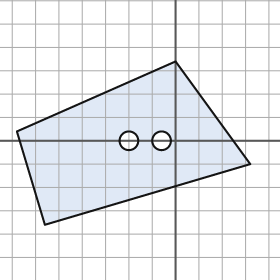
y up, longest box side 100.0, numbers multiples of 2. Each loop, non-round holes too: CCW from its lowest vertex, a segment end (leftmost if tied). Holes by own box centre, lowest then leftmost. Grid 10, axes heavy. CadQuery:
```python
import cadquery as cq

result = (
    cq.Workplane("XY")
    .moveTo(-56.0, -36.0)
    .lineTo(32.0, -10.0)
    .lineTo(0.0, 34.0)
    .lineTo(-68.0, 4.0)
    .close()
    .moveTo(-20.0, 0.0)
    .circle(4.0)
    .moveTo(-6.0, 0.0)
    .circle(4.0)
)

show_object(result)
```